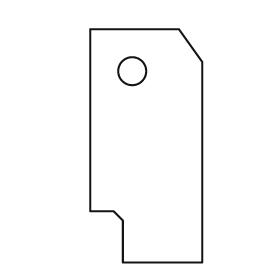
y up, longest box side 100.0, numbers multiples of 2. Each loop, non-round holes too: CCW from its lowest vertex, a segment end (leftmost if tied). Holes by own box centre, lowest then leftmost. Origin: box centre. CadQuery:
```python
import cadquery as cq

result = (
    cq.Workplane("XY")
    .moveTo(-10.0, -50.0)
    .lineTo(24.0, -50.0)
    .lineTo(24.0, 36.0)
    .lineTo(14.0, 50.0)
    .lineTo(-24.0, 50.0)
    .lineTo(-24.0, -28.0)
    .lineTo(-14.0, -28.0)
    .lineTo(-10.0, -32.0)
    .close()
    .moveTo(-6.0, 32.0)
    .circle(6.0)
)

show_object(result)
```